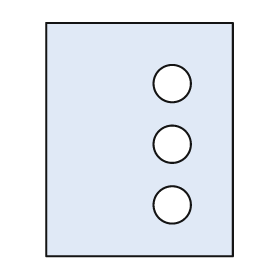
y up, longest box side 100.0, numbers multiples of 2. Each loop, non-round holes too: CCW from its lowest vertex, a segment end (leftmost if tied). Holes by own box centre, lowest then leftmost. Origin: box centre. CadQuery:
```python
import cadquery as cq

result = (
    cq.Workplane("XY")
    .moveTo(-40.0, -50.0)
    .lineTo(40.0, -50.0)
    .lineTo(40.0, 50.0)
    .lineTo(-40.0, 50.0)
    .close()
    .moveTo(14.0, -28.0)
    .circle(8.0)
    .moveTo(14.0, -2.0)
    .circle(8.0)
    .moveTo(14.0, 24.0)
    .circle(8.0)
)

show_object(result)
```